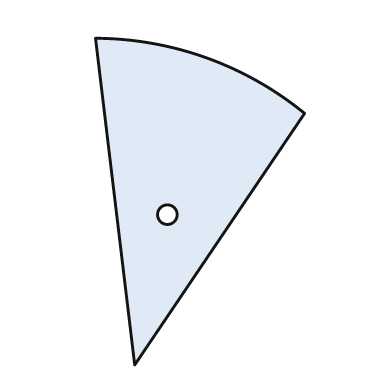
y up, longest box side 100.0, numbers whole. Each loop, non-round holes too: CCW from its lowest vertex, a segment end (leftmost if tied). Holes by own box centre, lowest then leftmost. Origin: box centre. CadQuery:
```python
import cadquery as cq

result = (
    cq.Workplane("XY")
    .moveTo(-20.0, -50.0)
    .lineTo(32.0, 27.0)
    .threePointArc((2.0, 44.0), (-32.0, 50.0))
    .close()
    .moveTo(-10.0, -4.0)
    .circle(3.0)
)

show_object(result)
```